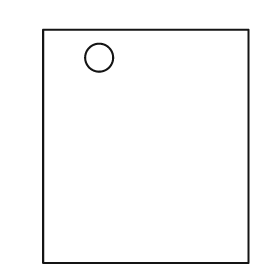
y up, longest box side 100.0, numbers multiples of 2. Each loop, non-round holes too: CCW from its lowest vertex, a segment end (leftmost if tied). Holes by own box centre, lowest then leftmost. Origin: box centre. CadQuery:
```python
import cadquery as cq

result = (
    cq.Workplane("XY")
    .moveTo(-44.0, -50.0)
    .lineTo(44.0, -50.0)
    .lineTo(44.0, 50.0)
    .lineTo(-44.0, 50.0)
    .close()
    .moveTo(-20.0, 38.0)
    .circle(6.0)
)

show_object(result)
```